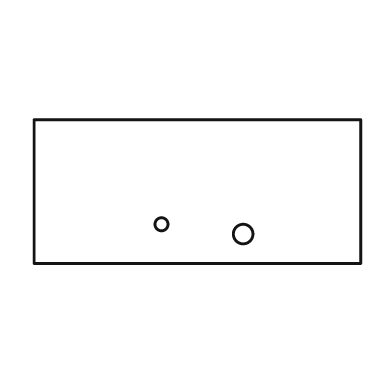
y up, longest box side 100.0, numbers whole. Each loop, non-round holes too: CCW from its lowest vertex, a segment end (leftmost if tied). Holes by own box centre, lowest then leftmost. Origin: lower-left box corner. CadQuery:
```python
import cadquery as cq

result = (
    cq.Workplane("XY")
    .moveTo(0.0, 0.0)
    .lineTo(100.0, 0.0)
    .lineTo(100.0, 44.0)
    .lineTo(0.0, 44.0)
    .close()
    .moveTo(64.0, 9.0)
    .circle(3.0)
    .moveTo(39.0, 12.0)
    .circle(2.0)
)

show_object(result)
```